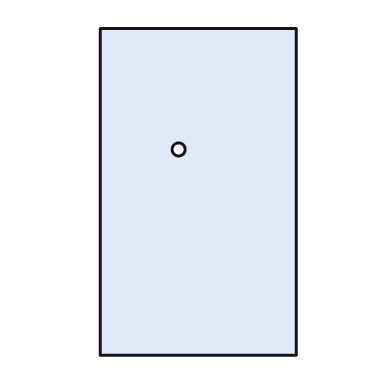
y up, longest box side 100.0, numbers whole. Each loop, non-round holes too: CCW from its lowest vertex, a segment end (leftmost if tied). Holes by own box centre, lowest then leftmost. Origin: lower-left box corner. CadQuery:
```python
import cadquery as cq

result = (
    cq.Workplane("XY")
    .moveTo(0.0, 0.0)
    .lineTo(60.0, 0.0)
    .lineTo(60.0, 100.0)
    .lineTo(0.0, 100.0)
    .close()
    .moveTo(24.0, 63.0)
    .circle(2.0)
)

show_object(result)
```